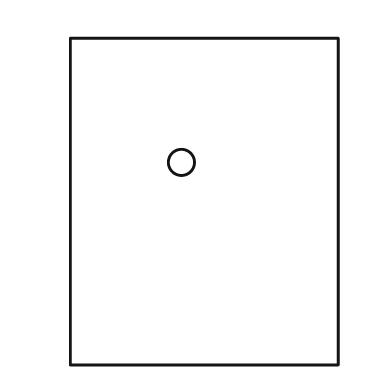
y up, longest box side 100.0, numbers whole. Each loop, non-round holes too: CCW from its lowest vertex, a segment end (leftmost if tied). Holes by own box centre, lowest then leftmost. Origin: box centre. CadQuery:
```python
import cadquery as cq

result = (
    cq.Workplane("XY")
    .moveTo(-41.0, -50.0)
    .lineTo(41.0, -50.0)
    .lineTo(41.0, 50.0)
    .lineTo(-41.0, 50.0)
    .close()
    .moveTo(-7.0, 12.0)
    .circle(4.0)
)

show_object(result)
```